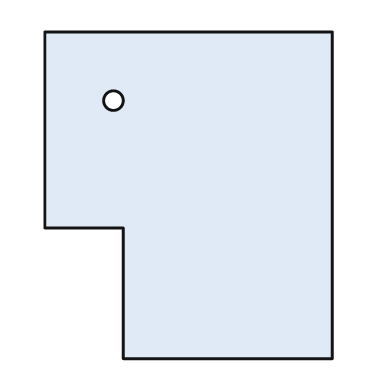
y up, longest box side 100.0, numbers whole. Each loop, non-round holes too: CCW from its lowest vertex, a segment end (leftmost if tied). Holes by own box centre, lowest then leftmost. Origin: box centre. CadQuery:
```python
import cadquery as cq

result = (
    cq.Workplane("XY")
    .moveTo(-20.0, -50.0)
    .lineTo(44.0, -50.0)
    .lineTo(44.0, 50.0)
    .lineTo(-44.0, 50.0)
    .lineTo(-44.0, -10.0)
    .lineTo(-20.0, -10.0)
    .close()
    .moveTo(-23.0, 29.0)
    .circle(3.0)
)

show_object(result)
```